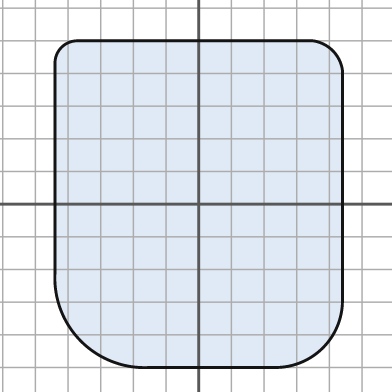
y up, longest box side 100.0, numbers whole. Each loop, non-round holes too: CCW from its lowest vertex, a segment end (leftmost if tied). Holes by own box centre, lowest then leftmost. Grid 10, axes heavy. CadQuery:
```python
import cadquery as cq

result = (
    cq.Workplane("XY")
    .moveTo(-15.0, -50.0)
    .lineTo(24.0, -50.0)
    .threePointArc((38.0, -44.0), (44.0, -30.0))
    .lineTo(44.0, 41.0)
    .threePointArc((41.0, 47.0), (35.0, 50.0))
    .lineTo(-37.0, 50.0)
    .threePointArc((-42.0, 48.0), (-44.0, 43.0))
    .lineTo(-44.0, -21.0)
    .threePointArc((-36.0, -42.0), (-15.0, -50.0))
    .close()
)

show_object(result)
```